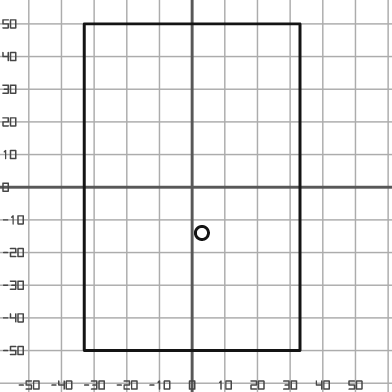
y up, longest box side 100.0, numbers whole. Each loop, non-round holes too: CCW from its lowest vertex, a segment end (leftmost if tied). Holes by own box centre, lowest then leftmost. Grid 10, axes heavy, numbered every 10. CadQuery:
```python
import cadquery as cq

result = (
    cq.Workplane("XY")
    .moveTo(-33.0, -50.0)
    .lineTo(33.0, -50.0)
    .lineTo(33.0, 50.0)
    .lineTo(-33.0, 50.0)
    .close()
    .moveTo(3.0, -14.0)
    .circle(2.0)
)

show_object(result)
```